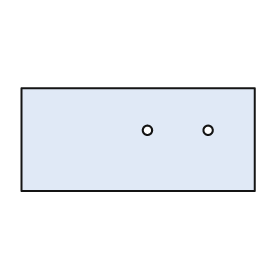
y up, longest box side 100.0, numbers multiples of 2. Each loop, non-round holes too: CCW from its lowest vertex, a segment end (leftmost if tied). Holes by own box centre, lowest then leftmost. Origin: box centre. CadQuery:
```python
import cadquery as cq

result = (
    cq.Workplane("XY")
    .moveTo(-50.0, -22.0)
    .lineTo(50.0, -22.0)
    .lineTo(50.0, 22.0)
    .lineTo(-50.0, 22.0)
    .close()
    .moveTo(4.0, 4.0)
    .circle(2.0)
    .moveTo(30.0, 4.0)
    .circle(2.0)
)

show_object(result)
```